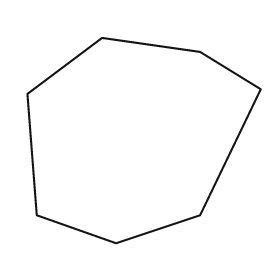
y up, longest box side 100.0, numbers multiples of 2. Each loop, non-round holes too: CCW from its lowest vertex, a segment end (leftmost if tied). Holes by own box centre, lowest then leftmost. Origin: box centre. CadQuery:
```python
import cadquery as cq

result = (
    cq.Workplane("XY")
    .moveTo(-12.0, -44.0)
    .lineTo(24.0, -32.0)
    .lineTo(50.0, 22.0)
    .lineTo(24.0, 38.0)
    .lineTo(-18.0, 44.0)
    .lineTo(-50.0, 20.0)
    .lineTo(-46.0, -32.0)
    .close()
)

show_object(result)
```